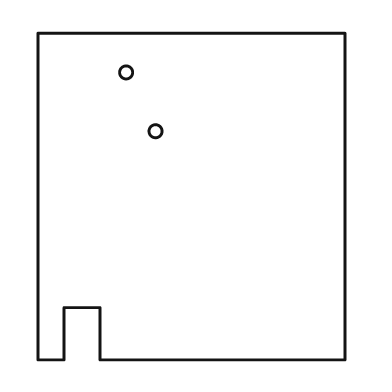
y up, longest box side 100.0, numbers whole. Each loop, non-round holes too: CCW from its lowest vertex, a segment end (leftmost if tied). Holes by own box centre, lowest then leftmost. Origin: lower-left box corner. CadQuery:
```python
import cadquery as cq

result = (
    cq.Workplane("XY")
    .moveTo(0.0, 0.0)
    .lineTo(8.0, 0.0)
    .lineTo(8.0, 16.0)
    .lineTo(19.0, 16.0)
    .lineTo(19.0, 0.0)
    .lineTo(94.0, 0.0)
    .lineTo(94.0, 100.0)
    .lineTo(0.0, 100.0)
    .close()
    .moveTo(36.0, 70.0)
    .circle(2.0)
    .moveTo(27.0, 88.0)
    .circle(2.0)
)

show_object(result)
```